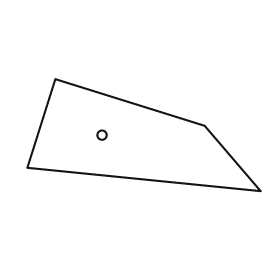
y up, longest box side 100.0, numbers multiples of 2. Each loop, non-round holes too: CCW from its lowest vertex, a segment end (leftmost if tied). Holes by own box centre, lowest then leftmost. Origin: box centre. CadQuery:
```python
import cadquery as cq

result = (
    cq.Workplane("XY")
    .moveTo(50.0, -24.0)
    .lineTo(26.0, 4.0)
    .lineTo(-38.0, 24.0)
    .lineTo(-50.0, -14.0)
    .close()
    .moveTo(-18.0, 0.0)
    .circle(2.0)
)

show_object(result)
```